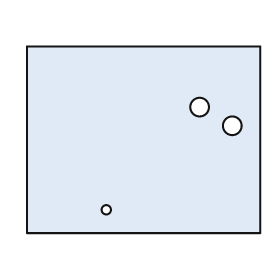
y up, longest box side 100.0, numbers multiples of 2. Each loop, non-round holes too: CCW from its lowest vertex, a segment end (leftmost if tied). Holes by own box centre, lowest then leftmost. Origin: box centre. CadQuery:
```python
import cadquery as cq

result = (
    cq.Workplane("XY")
    .moveTo(-50.0, -40.0)
    .lineTo(50.0, -40.0)
    .lineTo(50.0, 40.0)
    .lineTo(-50.0, 40.0)
    .close()
    .moveTo(-16.0, -30.0)
    .circle(2.0)
    .moveTo(38.0, 6.0)
    .circle(4.0)
    .moveTo(24.0, 14.0)
    .circle(4.0)
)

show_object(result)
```